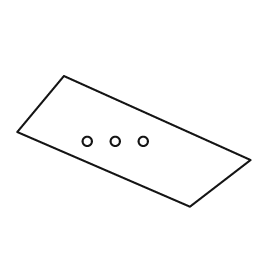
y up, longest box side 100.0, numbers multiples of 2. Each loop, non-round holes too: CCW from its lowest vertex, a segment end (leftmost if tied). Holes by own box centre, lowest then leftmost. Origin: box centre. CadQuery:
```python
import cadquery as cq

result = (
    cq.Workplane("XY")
    .moveTo(24.0, -28.0)
    .lineTo(50.0, -8.0)
    .lineTo(-30.0, 28.0)
    .lineTo(-50.0, 4.0)
    .close()
    .moveTo(-20.0, 0.0)
    .circle(2.0)
    .moveTo(-8.0, 0.0)
    .circle(2.0)
    .moveTo(4.0, 0.0)
    .circle(2.0)
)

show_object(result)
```